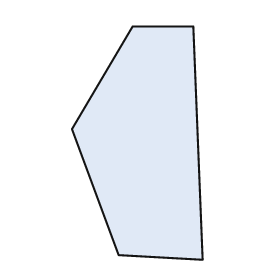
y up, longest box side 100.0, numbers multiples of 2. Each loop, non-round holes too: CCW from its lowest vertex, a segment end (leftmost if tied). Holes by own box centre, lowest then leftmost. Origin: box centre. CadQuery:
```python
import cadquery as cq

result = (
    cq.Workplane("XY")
    .moveTo(28.0, -50.0)
    .lineTo(24.0, 50.0)
    .lineTo(-2.0, 50.0)
    .lineTo(-28.0, 6.0)
    .lineTo(-8.0, -48.0)
    .close()
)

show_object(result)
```